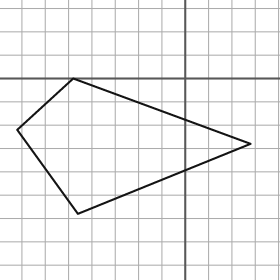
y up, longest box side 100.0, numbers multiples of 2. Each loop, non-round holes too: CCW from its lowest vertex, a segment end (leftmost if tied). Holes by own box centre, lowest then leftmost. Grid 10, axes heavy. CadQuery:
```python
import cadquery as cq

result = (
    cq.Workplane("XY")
    .moveTo(-46.0, -58.0)
    .lineTo(28.0, -28.0)
    .lineTo(-48.0, 0.0)
    .lineTo(-72.0, -22.0)
    .close()
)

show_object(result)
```